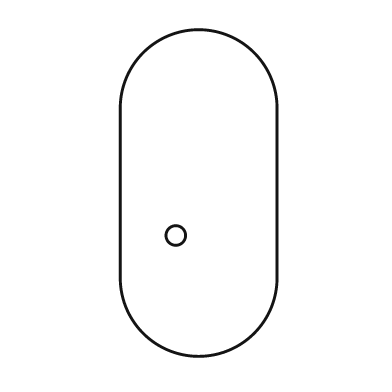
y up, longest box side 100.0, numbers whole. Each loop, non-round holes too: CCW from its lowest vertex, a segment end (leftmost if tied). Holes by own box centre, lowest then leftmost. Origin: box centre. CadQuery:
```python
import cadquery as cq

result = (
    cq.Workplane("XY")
    .moveTo(-24.0, -26.0)
    .threePointArc((0.0, -50.0), (24.0, -26.0))
    .lineTo(24.0, 26.0)
    .threePointArc((0.0, 50.0), (-24.0, 26.0))
    .close()
    .moveTo(-7.0, -13.0)
    .circle(3.0)
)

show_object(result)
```